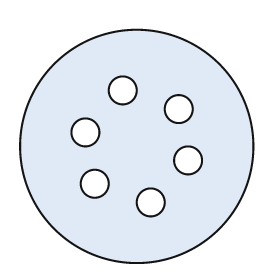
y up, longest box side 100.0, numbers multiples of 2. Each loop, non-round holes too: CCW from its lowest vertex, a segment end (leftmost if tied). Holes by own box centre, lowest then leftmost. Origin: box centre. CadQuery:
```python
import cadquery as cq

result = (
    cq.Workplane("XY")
    .moveTo(0.0, 0.0)
    .circle(50.0)
    .moveTo(6.0, -24.0)
    .circle(6.0)
    .moveTo(-18.0, -16.0)
    .circle(6.0)
    .moveTo(22.0, -6.0)
    .circle(6.0)
    .moveTo(-22.0, 6.0)
    .circle(6.0)
    .moveTo(18.0, 16.0)
    .circle(6.0)
    .moveTo(-6.0, 24.0)
    .circle(6.0)
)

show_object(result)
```